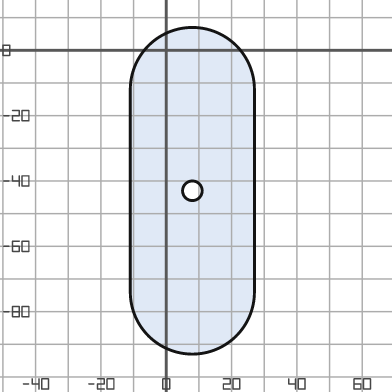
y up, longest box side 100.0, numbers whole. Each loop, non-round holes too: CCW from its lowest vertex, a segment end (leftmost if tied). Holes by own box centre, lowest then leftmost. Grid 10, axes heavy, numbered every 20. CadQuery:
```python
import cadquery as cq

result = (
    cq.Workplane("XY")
    .moveTo(-11.0, -74.0)
    .threePointArc((8.0, -93.0), (27.0, -74.0))
    .lineTo(27.0, -12.0)
    .threePointArc((8.0, 7.0), (-11.0, -12.0))
    .close()
    .moveTo(8.0, -43.0)
    .circle(3.0)
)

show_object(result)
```